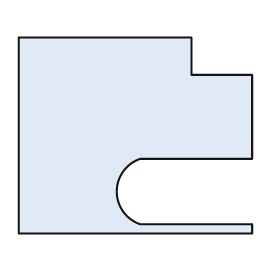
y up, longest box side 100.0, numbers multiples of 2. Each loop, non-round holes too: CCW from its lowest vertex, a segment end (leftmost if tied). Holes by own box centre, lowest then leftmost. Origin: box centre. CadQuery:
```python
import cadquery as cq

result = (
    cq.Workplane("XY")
    .moveTo(-50.0, -42.0)
    .lineTo(50.0, -42.0)
    .lineTo(50.0, -38.0)
    .lineTo(2.0, -38.0)
    .threePointArc((-8.0, -24.0), (2.0, -10.0))
    .lineTo(50.0, -10.0)
    .lineTo(50.0, 26.0)
    .lineTo(24.0, 26.0)
    .lineTo(24.0, 42.0)
    .lineTo(-50.0, 42.0)
    .close()
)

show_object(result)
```